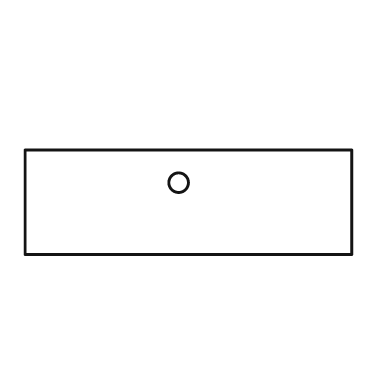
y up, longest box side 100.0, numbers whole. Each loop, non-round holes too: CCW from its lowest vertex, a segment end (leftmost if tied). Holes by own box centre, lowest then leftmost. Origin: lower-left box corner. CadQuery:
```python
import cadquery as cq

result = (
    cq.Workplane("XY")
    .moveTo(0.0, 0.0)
    .lineTo(100.0, 0.0)
    .lineTo(100.0, 32.0)
    .lineTo(0.0, 32.0)
    .close()
    .moveTo(47.0, 22.0)
    .circle(3.0)
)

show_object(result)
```